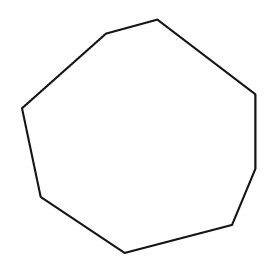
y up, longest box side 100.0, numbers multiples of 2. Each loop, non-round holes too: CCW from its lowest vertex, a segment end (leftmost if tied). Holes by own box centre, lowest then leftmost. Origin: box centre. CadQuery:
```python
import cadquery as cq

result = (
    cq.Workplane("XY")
    .moveTo(-6.0, -50.0)
    .lineTo(40.0, -38.0)
    .lineTo(50.0, -14.0)
    .lineTo(50.0, 18.0)
    .lineTo(8.0, 50.0)
    .lineTo(-14.0, 44.0)
    .lineTo(-50.0, 12.0)
    .lineTo(-42.0, -26.0)
    .close()
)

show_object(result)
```